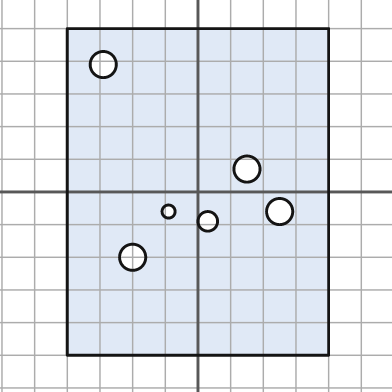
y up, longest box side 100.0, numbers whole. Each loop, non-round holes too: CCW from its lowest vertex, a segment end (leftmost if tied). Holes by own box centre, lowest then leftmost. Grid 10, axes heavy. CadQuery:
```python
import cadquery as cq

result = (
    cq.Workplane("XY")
    .moveTo(-40.0, -50.0)
    .lineTo(40.0, -50.0)
    .lineTo(40.0, 50.0)
    .lineTo(-40.0, 50.0)
    .close()
    .moveTo(-20.0, -20.0)
    .circle(4.0)
    .moveTo(3.0, -9.0)
    .circle(3.0)
    .moveTo(-9.0, -6.0)
    .circle(2.0)
    .moveTo(25.0, -6.0)
    .circle(4.0)
    .moveTo(15.0, 7.0)
    .circle(4.0)
    .moveTo(-29.0, 39.0)
    .circle(4.0)
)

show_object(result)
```